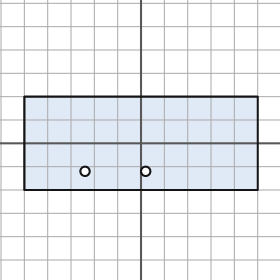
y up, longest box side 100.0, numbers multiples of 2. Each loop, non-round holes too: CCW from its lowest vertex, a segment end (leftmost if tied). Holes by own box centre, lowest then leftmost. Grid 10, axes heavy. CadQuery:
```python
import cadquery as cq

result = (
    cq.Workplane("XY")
    .moveTo(-50.0, -20.0)
    .lineTo(50.0, -20.0)
    .lineTo(50.0, 20.0)
    .lineTo(-50.0, 20.0)
    .close()
    .moveTo(-24.0, -12.0)
    .circle(2.0)
    .moveTo(2.0, -12.0)
    .circle(2.0)
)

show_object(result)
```